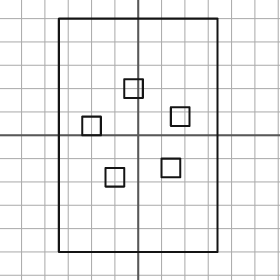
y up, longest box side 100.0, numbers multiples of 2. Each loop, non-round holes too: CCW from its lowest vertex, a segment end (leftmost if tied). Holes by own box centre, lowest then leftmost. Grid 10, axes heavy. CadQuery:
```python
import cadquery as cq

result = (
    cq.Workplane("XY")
    .moveTo(-34.0, -50.0)
    .lineTo(34.0, -50.0)
    .lineTo(34.0, 50.0)
    .lineTo(-34.0, 50.0)
    .close()
    .moveTo(-14.0, -22.0)
    .lineTo(-6.0, -22.0)
    .lineTo(-6.0, -14.0)
    .lineTo(-14.0, -14.0)
    .close()
    .moveTo(10.0, -18.0)
    .lineTo(18.0, -18.0)
    .lineTo(18.0, -10.0)
    .lineTo(10.0, -10.0)
    .close()
    .moveTo(-24.0, 0.0)
    .lineTo(-16.0, 0.0)
    .lineTo(-16.0, 8.0)
    .lineTo(-24.0, 8.0)
    .close()
    .moveTo(14.0, 4.0)
    .lineTo(22.0, 4.0)
    .lineTo(22.0, 12.0)
    .lineTo(14.0, 12.0)
    .close()
    .moveTo(-6.0, 16.0)
    .lineTo(2.0, 16.0)
    .lineTo(2.0, 24.0)
    .lineTo(-6.0, 24.0)
    .close()
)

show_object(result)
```